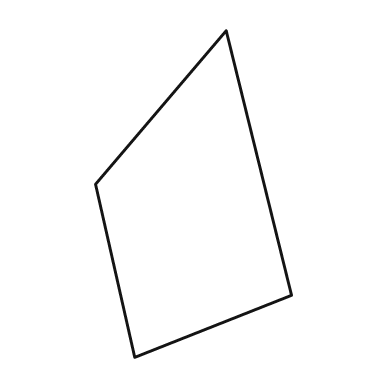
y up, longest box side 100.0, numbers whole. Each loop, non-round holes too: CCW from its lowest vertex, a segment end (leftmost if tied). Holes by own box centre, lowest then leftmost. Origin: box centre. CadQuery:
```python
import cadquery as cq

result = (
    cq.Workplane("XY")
    .moveTo(-18.0, -50.0)
    .lineTo(30.0, -31.0)
    .lineTo(10.0, 50.0)
    .lineTo(-30.0, 3.0)
    .close()
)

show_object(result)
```